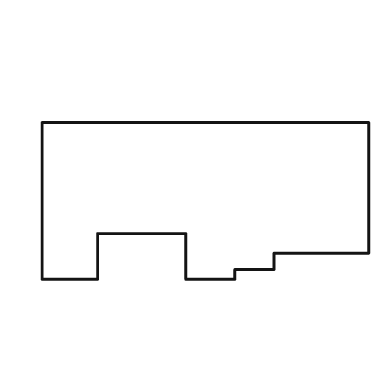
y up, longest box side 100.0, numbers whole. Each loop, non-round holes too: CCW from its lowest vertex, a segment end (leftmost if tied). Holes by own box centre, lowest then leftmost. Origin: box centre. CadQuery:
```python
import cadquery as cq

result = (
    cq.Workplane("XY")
    .moveTo(-50.0, -24.0)
    .lineTo(-33.0, -24.0)
    .lineTo(-33.0, -10.0)
    .lineTo(-6.0, -10.0)
    .lineTo(-6.0, -24.0)
    .lineTo(9.0, -24.0)
    .lineTo(9.0, -21.0)
    .lineTo(21.0, -21.0)
    .lineTo(21.0, -16.0)
    .lineTo(50.0, -16.0)
    .lineTo(50.0, 24.0)
    .lineTo(-50.0, 24.0)
    .close()
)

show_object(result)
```